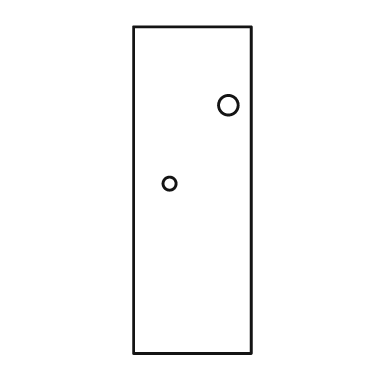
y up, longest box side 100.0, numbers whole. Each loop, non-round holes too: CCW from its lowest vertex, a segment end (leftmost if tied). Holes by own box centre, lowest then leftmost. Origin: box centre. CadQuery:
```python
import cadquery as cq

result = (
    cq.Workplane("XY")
    .moveTo(-18.0, -50.0)
    .lineTo(18.0, -50.0)
    .lineTo(18.0, 50.0)
    .lineTo(-18.0, 50.0)
    .close()
    .moveTo(-7.0, 2.0)
    .circle(2.0)
    .moveTo(11.0, 26.0)
    .circle(3.0)
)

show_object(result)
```